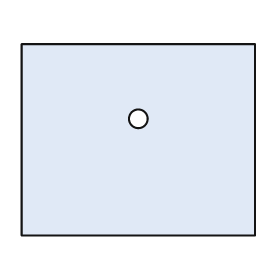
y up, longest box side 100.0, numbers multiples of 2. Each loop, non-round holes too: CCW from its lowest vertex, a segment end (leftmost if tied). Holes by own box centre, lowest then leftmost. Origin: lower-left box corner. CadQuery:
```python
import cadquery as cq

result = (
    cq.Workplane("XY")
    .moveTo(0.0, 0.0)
    .lineTo(100.0, 0.0)
    .lineTo(100.0, 82.0)
    .lineTo(0.0, 82.0)
    .close()
    .moveTo(50.0, 50.0)
    .circle(4.0)
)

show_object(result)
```